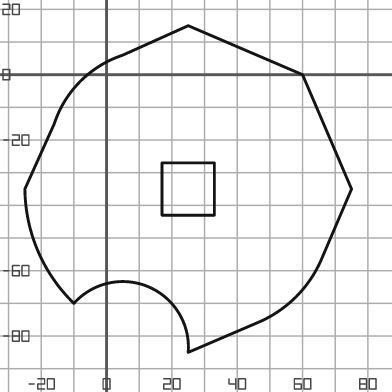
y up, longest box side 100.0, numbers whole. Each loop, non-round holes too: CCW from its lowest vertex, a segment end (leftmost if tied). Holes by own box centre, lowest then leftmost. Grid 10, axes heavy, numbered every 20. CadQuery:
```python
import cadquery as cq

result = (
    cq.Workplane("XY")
    .moveTo(25.0, -85.0)
    .lineTo(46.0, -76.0)
    .threePointArc((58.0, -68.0), (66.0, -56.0))
    .lineTo(75.0, -35.0)
    .lineTo(60.0, 0.0)
    .lineTo(25.0, 15.0)
    .lineTo(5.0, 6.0)
    .threePointArc((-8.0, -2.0), (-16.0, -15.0))
    .lineTo(-25.0, -35.0)
    .threePointArc((-21.0, -54.0), (-10.0, -70.0))
    .threePointArc((13.0, -65.0), (25.0, -85.0))
    .close()
    .moveTo(17.0, -43.0)
    .lineTo(33.0, -43.0)
    .lineTo(33.0, -27.0)
    .lineTo(17.0, -27.0)
    .close()
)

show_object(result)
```